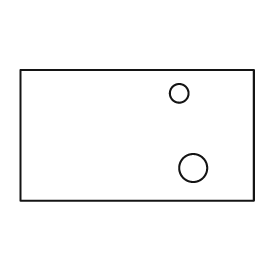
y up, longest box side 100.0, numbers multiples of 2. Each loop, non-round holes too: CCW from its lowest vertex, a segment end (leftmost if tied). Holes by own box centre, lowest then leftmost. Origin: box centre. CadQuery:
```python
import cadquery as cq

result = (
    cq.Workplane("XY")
    .moveTo(-50.0, -28.0)
    .lineTo(50.0, -28.0)
    .lineTo(50.0, 28.0)
    .lineTo(-50.0, 28.0)
    .close()
    .moveTo(24.0, -14.0)
    .circle(6.0)
    .moveTo(18.0, 18.0)
    .circle(4.0)
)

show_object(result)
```